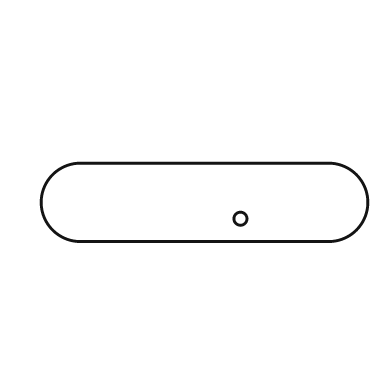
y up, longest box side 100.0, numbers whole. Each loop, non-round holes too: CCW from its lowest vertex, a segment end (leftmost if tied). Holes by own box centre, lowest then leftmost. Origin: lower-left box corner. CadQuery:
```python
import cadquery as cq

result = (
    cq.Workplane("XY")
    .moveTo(12.0, 0.0)
    .lineTo(88.0, 0.0)
    .threePointArc((100.0, 12.0), (88.0, 24.0))
    .lineTo(12.0, 24.0)
    .threePointArc((0.0, 12.0), (12.0, 0.0))
    .close()
    .moveTo(61.0, 7.0)
    .circle(2.0)
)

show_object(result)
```